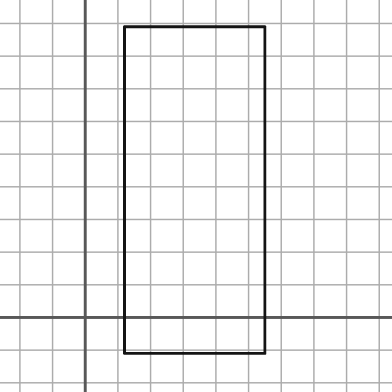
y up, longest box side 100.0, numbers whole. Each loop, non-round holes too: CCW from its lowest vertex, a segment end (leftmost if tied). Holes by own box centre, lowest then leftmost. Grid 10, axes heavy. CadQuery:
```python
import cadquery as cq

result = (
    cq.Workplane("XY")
    .moveTo(12.0, -11.0)
    .lineTo(55.0, -11.0)
    .lineTo(55.0, 89.0)
    .lineTo(12.0, 89.0)
    .close()
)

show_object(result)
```